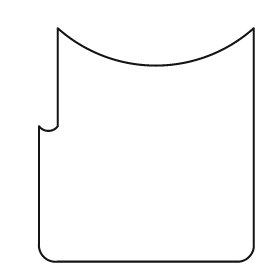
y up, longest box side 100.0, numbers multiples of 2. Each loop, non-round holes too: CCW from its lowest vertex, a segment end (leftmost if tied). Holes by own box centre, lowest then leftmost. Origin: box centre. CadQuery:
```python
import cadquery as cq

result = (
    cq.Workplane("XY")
    .moveTo(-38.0, -50.0)
    .lineTo(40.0, -50.0)
    .threePointArc((44.0, -48.0), (46.0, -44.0))
    .lineTo(46.0, 50.0)
    .threePointArc((4.0, 34.0), (-38.0, 50.0))
    .lineTo(-38.0, 8.0)
    .threePointArc((-42.0, 6.0), (-46.0, 8.0))
    .lineTo(-46.0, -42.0)
    .threePointArc((-44.0, -48.0), (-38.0, -50.0))
    .close()
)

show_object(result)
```